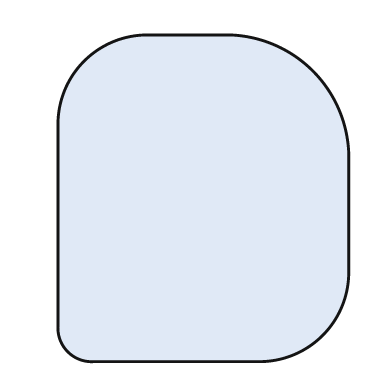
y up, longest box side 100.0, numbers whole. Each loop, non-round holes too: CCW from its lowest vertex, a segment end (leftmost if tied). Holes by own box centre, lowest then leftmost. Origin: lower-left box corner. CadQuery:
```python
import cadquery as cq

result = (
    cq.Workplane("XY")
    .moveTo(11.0, 0.0)
    .lineTo(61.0, 0.0)
    .threePointArc((81.0, 8.0), (89.0, 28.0))
    .lineTo(89.0, 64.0)
    .threePointArc((78.0, 89.0), (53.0, 100.0))
    .lineTo(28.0, 100.0)
    .threePointArc((8.0, 92.0), (0.0, 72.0))
    .lineTo(0.0, 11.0)
    .threePointArc((3.0, 3.0), (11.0, 0.0))
    .close()
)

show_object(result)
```